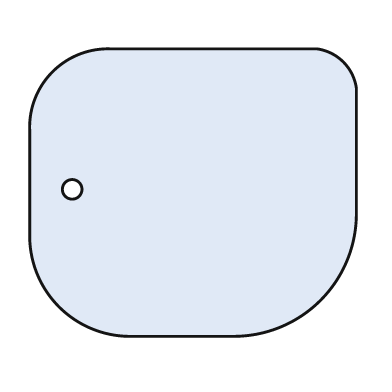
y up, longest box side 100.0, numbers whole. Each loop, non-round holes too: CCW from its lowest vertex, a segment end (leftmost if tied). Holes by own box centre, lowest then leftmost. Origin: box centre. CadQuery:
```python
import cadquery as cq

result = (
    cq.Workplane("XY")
    .moveTo(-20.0, -44.0)
    .lineTo(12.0, -44.0)
    .threePointArc((39.0, -33.0), (50.0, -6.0))
    .lineTo(50.0, 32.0)
    .threePointArc((46.0, 40.0), (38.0, 44.0))
    .lineTo(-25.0, 44.0)
    .threePointArc((-43.0, 37.0), (-50.0, 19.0))
    .lineTo(-50.0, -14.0)
    .threePointArc((-41.0, -35.0), (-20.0, -44.0))
    .close()
    .moveTo(-37.0, 1.0)
    .circle(3.0)
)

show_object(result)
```